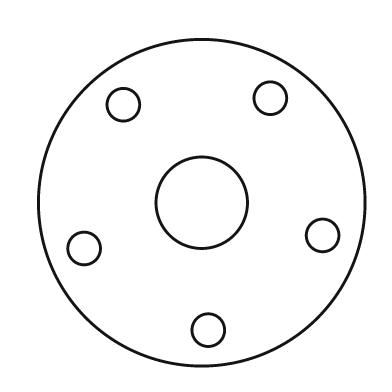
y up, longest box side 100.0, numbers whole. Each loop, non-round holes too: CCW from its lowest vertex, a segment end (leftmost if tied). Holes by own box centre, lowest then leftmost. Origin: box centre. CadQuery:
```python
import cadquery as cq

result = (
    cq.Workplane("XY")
    .moveTo(0.0, 0.0)
    .circle(50.0)
    .moveTo(2.0, -39.0)
    .circle(5.0)
    .moveTo(-36.0, -14.0)
    .circle(5.0)
    .moveTo(37.0, -10.0)
    .circle(5.0)
    .moveTo(0.0, 0.0)
    .circle(14.0)
    .moveTo(-24.0, 30.0)
    .circle(5.0)
    .moveTo(21.0, 32.0)
    .circle(5.0)
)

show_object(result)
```